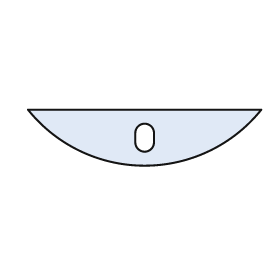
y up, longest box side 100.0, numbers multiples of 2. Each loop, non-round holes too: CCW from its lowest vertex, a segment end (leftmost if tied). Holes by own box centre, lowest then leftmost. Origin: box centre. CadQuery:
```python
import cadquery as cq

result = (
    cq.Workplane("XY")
    .moveTo(-50.0, 12.0)
    .threePointArc((0.0, -12.0), (50.0, 12.0))
    .close()
    .moveTo(-4.0, -2.0)
    .threePointArc((0.0, -6.0), (4.0, -2.0))
    .lineTo(4.0, 2.0)
    .threePointArc((0.0, 6.0), (-4.0, 2.0))
    .close()
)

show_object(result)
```